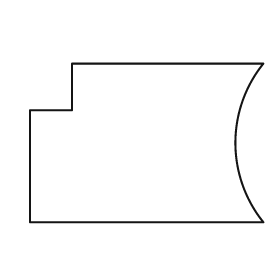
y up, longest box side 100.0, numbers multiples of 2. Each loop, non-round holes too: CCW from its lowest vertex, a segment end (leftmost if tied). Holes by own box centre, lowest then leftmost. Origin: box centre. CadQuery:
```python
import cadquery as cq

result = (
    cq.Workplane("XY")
    .moveTo(-50.0, -34.0)
    .lineTo(50.0, -34.0)
    .threePointArc((38.0, 0.0), (50.0, 34.0))
    .lineTo(-32.0, 34.0)
    .lineTo(-32.0, 14.0)
    .lineTo(-50.0, 14.0)
    .close()
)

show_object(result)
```